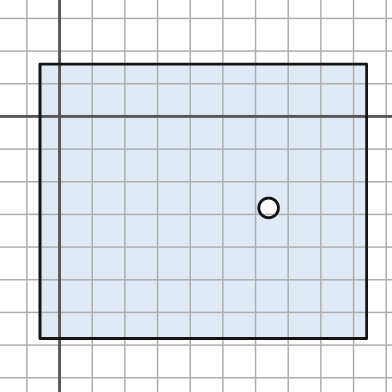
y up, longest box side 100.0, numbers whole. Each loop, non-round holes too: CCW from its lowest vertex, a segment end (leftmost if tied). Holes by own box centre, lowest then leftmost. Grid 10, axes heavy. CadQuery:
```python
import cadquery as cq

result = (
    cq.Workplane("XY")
    .moveTo(-6.0, -68.0)
    .lineTo(94.0, -68.0)
    .lineTo(94.0, 16.0)
    .lineTo(-6.0, 16.0)
    .close()
    .moveTo(64.0, -28.0)
    .circle(3.0)
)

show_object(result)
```